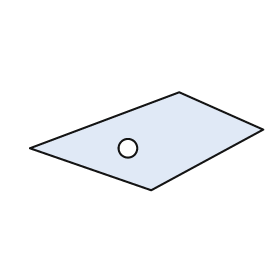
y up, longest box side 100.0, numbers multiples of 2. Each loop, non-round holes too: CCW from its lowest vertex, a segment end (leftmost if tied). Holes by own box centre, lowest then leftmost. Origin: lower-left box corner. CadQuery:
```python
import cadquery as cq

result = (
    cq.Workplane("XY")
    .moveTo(52.0, 0.0)
    .lineTo(100.0, 26.0)
    .lineTo(64.0, 42.0)
    .lineTo(0.0, 18.0)
    .close()
    .moveTo(42.0, 18.0)
    .circle(4.0)
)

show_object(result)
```